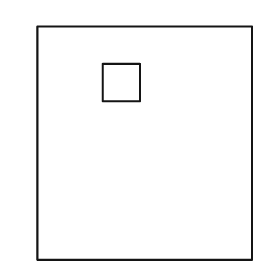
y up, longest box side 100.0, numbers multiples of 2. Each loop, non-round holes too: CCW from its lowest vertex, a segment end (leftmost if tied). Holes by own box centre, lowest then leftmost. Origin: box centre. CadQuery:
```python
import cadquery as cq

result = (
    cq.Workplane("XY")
    .moveTo(-46.0, -50.0)
    .lineTo(46.0, -50.0)
    .lineTo(46.0, 50.0)
    .lineTo(-46.0, 50.0)
    .close()
    .moveTo(-18.0, 18.0)
    .lineTo(-2.0, 18.0)
    .lineTo(-2.0, 34.0)
    .lineTo(-18.0, 34.0)
    .close()
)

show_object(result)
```